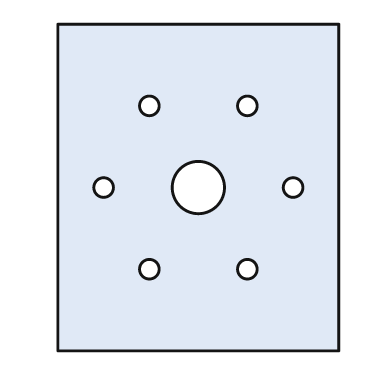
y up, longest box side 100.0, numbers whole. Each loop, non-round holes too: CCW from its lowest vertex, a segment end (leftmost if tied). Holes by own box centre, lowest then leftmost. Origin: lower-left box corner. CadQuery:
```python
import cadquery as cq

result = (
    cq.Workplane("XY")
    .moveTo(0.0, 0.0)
    .lineTo(86.0, 0.0)
    .lineTo(86.0, 100.0)
    .lineTo(0.0, 100.0)
    .close()
    .moveTo(28.0, 25.0)
    .circle(3.0)
    .moveTo(58.0, 25.0)
    .circle(3.0)
    .moveTo(14.0, 50.0)
    .circle(3.0)
    .moveTo(43.0, 50.0)
    .circle(8.0)
    .moveTo(72.0, 50.0)
    .circle(3.0)
    .moveTo(28.0, 75.0)
    .circle(3.0)
    .moveTo(58.0, 75.0)
    .circle(3.0)
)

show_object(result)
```